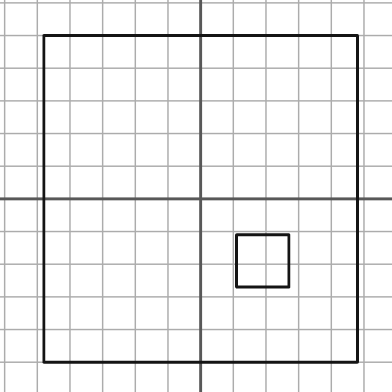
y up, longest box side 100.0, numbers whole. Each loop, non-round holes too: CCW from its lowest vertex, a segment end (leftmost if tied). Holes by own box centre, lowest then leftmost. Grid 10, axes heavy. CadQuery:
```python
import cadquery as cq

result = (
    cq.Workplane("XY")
    .moveTo(-48.0, -50.0)
    .lineTo(48.0, -50.0)
    .lineTo(48.0, 50.0)
    .lineTo(-48.0, 50.0)
    .close()
    .moveTo(11.0, -27.0)
    .lineTo(27.0, -27.0)
    .lineTo(27.0, -11.0)
    .lineTo(11.0, -11.0)
    .close()
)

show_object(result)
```